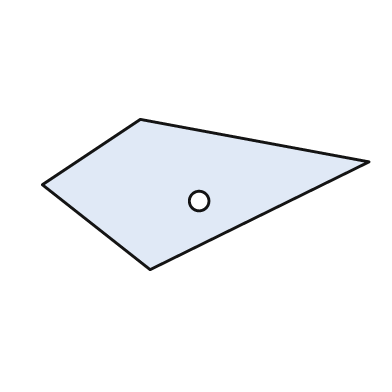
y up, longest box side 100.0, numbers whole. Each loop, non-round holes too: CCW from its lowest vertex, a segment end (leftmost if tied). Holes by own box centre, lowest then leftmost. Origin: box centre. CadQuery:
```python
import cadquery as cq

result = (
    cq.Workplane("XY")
    .moveTo(-17.0, -23.0)
    .lineTo(50.0, 10.0)
    .lineTo(-20.0, 23.0)
    .lineTo(-50.0, 3.0)
    .close()
    .moveTo(-2.0, -2.0)
    .circle(3.0)
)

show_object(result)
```